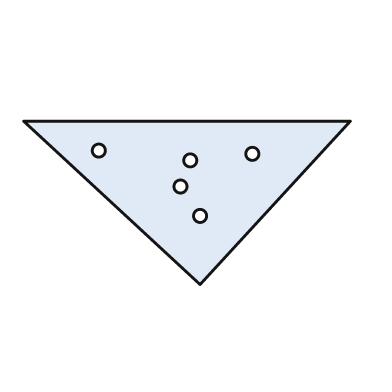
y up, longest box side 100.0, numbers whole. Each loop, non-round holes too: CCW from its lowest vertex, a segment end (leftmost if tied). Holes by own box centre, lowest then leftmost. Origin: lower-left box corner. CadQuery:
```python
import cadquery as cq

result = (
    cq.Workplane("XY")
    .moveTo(54.0, 0.0)
    .lineTo(100.0, 50.0)
    .lineTo(0.0, 50.0)
    .close()
    .moveTo(54.0, 21.0)
    .circle(2.0)
    .moveTo(48.0, 30.0)
    .circle(2.0)
    .moveTo(51.0, 38.0)
    .circle(2.0)
    .moveTo(70.0, 40.0)
    .circle(2.0)
    .moveTo(23.0, 41.0)
    .circle(2.0)
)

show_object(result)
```